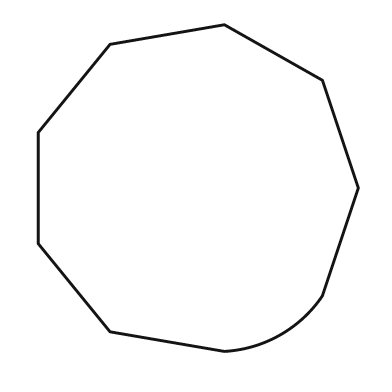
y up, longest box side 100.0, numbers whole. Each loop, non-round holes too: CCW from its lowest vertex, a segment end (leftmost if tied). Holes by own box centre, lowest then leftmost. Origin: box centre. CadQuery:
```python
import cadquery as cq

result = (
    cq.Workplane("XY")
    .moveTo(8.0, -50.0)
    .threePointArc((25.0, -45.0), (38.0, -33.0))
    .lineTo(49.0, 0.0)
    .lineTo(38.0, 33.0)
    .lineTo(8.0, 50.0)
    .lineTo(-27.0, 44.0)
    .lineTo(-49.0, 17.0)
    .lineTo(-49.0, -17.0)
    .lineTo(-27.0, -44.0)
    .close()
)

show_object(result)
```